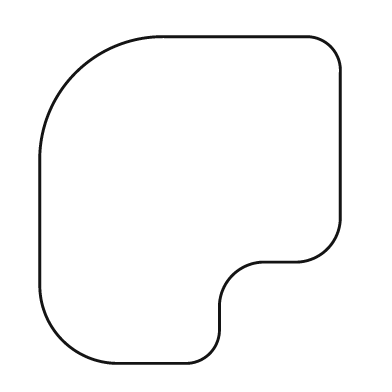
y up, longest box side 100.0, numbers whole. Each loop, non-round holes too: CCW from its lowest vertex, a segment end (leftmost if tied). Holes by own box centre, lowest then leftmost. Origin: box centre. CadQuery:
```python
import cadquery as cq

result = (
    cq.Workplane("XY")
    .moveTo(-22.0, -50.0)
    .lineTo(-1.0, -50.0)
    .threePointArc((6.0, -47.0), (9.0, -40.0))
    .lineTo(9.0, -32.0)
    .threePointArc((13.0, -23.0), (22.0, -19.0))
    .lineTo(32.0, -19.0)
    .threePointArc((42.0, -15.0), (46.0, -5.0))
    .lineTo(46.0, 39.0)
    .threePointArc((43.0, 47.0), (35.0, 50.0))
    .lineTo(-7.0, 50.0)
    .threePointArc((-35.0, 39.0), (-46.0, 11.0))
    .lineTo(-46.0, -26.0)
    .threePointArc((-39.0, -43.0), (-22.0, -50.0))
    .close()
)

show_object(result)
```